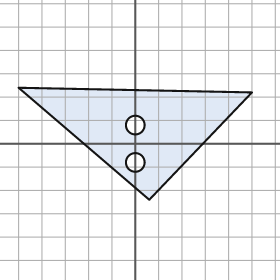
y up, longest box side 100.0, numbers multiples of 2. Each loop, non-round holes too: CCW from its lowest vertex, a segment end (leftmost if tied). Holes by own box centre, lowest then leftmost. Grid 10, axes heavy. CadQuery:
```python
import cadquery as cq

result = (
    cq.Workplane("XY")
    .moveTo(6.0, -24.0)
    .lineTo(50.0, 22.0)
    .lineTo(-50.0, 24.0)
    .close()
    .moveTo(0.0, -8.0)
    .circle(4.0)
    .moveTo(0.0, 8.0)
    .circle(4.0)
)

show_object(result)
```